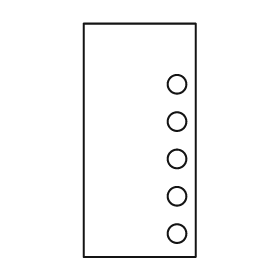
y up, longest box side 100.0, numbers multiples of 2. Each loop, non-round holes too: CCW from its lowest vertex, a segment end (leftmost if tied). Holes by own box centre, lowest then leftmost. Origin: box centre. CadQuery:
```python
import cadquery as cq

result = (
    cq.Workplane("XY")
    .moveTo(-24.0, -50.0)
    .lineTo(24.0, -50.0)
    .lineTo(24.0, 50.0)
    .lineTo(-24.0, 50.0)
    .close()
    .moveTo(16.0, -40.0)
    .circle(4.0)
    .moveTo(16.0, -24.0)
    .circle(4.0)
    .moveTo(16.0, -8.0)
    .circle(4.0)
    .moveTo(16.0, 8.0)
    .circle(4.0)
    .moveTo(16.0, 24.0)
    .circle(4.0)
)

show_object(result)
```